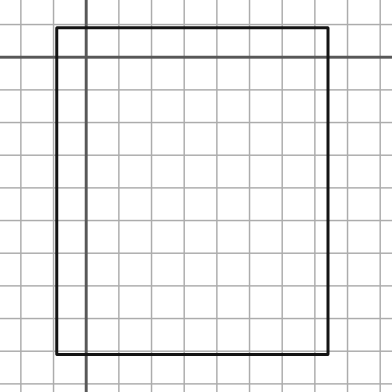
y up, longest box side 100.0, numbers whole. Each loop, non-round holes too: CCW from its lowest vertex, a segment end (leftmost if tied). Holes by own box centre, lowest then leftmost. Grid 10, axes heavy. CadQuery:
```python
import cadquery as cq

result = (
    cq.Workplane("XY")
    .moveTo(-9.0, -91.0)
    .lineTo(74.0, -91.0)
    .lineTo(74.0, 9.0)
    .lineTo(-9.0, 9.0)
    .close()
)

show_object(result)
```